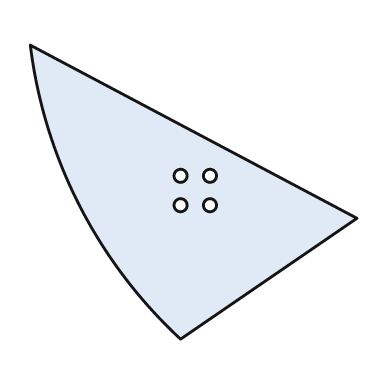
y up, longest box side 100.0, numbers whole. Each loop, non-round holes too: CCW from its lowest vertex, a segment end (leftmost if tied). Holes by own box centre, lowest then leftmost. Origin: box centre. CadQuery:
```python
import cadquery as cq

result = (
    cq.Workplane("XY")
    .moveTo(-4.0, -45.0)
    .lineTo(50.0, -8.0)
    .lineTo(-50.0, 45.0)
    .threePointArc((-35.0, -4.0), (-4.0, -45.0))
    .close()
    .moveTo(-4.0, -4.0)
    .circle(2.0)
    .moveTo(5.0, -4.0)
    .circle(2.0)
    .moveTo(-4.0, 5.0)
    .circle(2.0)
    .moveTo(5.0, 5.0)
    .circle(2.0)
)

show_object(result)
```